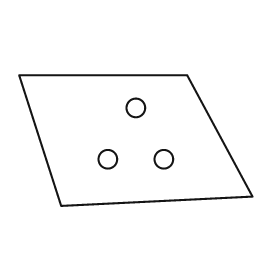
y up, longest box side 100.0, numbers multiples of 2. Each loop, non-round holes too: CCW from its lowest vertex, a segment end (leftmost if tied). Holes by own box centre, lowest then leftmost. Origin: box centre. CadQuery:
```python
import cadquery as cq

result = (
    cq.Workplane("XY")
    .moveTo(-32.0, -28.0)
    .lineTo(50.0, -24.0)
    .lineTo(22.0, 28.0)
    .lineTo(-50.0, 28.0)
    .close()
    .moveTo(-12.0, -8.0)
    .circle(4.0)
    .moveTo(12.0, -8.0)
    .circle(4.0)
    .moveTo(0.0, 14.0)
    .circle(4.0)
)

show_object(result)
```